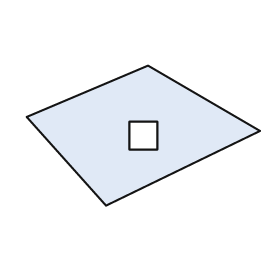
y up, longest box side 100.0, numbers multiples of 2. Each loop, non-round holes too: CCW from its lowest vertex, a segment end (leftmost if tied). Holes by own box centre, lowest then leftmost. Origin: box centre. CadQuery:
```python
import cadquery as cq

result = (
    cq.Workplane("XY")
    .moveTo(-16.0, -30.0)
    .lineTo(50.0, 2.0)
    .lineTo(2.0, 30.0)
    .lineTo(-50.0, 8.0)
    .close()
    .moveTo(-6.0, -6.0)
    .lineTo(6.0, -6.0)
    .lineTo(6.0, 6.0)
    .lineTo(-6.0, 6.0)
    .close()
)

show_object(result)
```